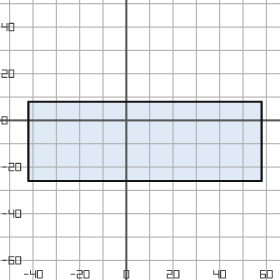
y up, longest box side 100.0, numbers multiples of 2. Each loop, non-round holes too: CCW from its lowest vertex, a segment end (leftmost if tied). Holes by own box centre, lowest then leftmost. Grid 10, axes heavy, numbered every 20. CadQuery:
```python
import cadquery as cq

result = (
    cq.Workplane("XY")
    .moveTo(-42.0, -26.0)
    .lineTo(58.0, -26.0)
    .lineTo(58.0, 8.0)
    .lineTo(-42.0, 8.0)
    .close()
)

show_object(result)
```